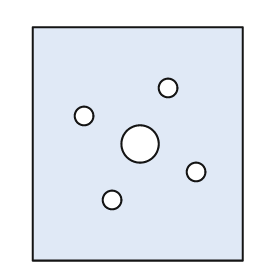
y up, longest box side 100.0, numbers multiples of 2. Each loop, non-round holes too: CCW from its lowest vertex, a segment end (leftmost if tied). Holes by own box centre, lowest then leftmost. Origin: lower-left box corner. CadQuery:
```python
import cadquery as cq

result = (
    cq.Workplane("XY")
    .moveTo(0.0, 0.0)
    .lineTo(90.0, 0.0)
    .lineTo(90.0, 100.0)
    .lineTo(0.0, 100.0)
    .close()
    .moveTo(34.0, 26.0)
    .circle(4.0)
    .moveTo(70.0, 38.0)
    .circle(4.0)
    .moveTo(46.0, 50.0)
    .circle(8.0)
    .moveTo(22.0, 62.0)
    .circle(4.0)
    .moveTo(58.0, 74.0)
    .circle(4.0)
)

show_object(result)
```